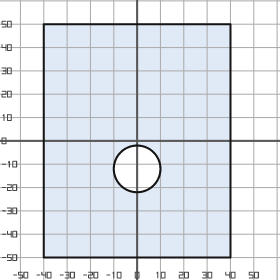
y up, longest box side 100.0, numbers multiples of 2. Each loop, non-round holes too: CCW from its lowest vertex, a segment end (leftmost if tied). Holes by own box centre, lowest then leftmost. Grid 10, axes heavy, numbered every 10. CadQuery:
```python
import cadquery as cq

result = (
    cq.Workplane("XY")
    .moveTo(-40.0, -50.0)
    .lineTo(40.0, -50.0)
    .lineTo(40.0, 50.0)
    .lineTo(-40.0, 50.0)
    .close()
    .moveTo(0.0, -12.0)
    .circle(10.0)
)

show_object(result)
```